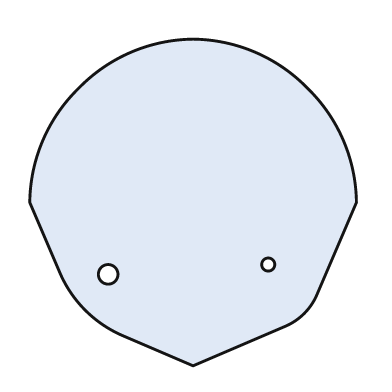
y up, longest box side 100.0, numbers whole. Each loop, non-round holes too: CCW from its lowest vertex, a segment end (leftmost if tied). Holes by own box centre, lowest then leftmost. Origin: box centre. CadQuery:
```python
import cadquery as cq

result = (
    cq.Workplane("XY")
    .moveTo(0.0, -50.0)
    .lineTo(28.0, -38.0)
    .threePointArc((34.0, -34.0), (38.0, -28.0))
    .lineTo(50.0, 0.0)
    .threePointArc((46.0, 19.0), (35.0, 35.0))
    .threePointArc((19.0, 46.0), (0.0, 50.0))
    .threePointArc((-19.0, 46.0), (-35.0, 35.0))
    .threePointArc((-46.0, 19.0), (-50.0, 0.0))
    .lineTo(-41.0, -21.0)
    .threePointArc((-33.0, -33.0), (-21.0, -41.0))
    .close()
    .moveTo(-26.0, -22.0)
    .circle(3.0)
    .moveTo(23.0, -19.0)
    .circle(2.0)
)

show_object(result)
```